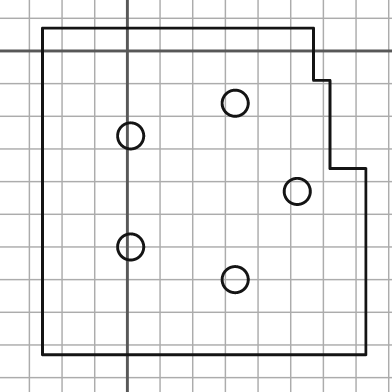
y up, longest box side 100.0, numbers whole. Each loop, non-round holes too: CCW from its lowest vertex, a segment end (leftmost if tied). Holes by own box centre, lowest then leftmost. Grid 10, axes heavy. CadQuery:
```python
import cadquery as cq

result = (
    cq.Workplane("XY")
    .moveTo(-26.0, -93.0)
    .lineTo(73.0, -93.0)
    .lineTo(73.0, -36.0)
    .lineTo(62.0, -36.0)
    .lineTo(62.0, -9.0)
    .lineTo(57.0, -9.0)
    .lineTo(57.0, 7.0)
    .lineTo(-26.0, 7.0)
    .close()
    .moveTo(33.0, -70.0)
    .circle(4.0)
    .moveTo(1.0, -60.0)
    .circle(4.0)
    .moveTo(52.0, -43.0)
    .circle(4.0)
    .moveTo(1.0, -26.0)
    .circle(4.0)
    .moveTo(33.0, -16.0)
    .circle(4.0)
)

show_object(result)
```